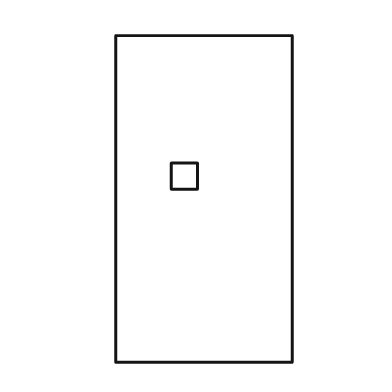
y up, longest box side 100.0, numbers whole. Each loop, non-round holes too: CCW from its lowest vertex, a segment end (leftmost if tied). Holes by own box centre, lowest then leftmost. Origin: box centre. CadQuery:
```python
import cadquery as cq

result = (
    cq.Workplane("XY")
    .moveTo(-27.0, -50.0)
    .lineTo(27.0, -50.0)
    .lineTo(27.0, 50.0)
    .lineTo(-27.0, 50.0)
    .close()
    .moveTo(-10.0, 3.0)
    .lineTo(-2.0, 3.0)
    .lineTo(-2.0, 11.0)
    .lineTo(-10.0, 11.0)
    .close()
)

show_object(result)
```